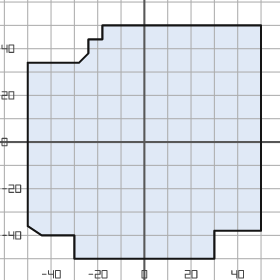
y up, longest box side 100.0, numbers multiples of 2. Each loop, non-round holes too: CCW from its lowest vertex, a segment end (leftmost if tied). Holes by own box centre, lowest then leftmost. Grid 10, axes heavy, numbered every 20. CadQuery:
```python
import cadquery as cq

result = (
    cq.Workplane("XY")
    .moveTo(-30.0, -50.0)
    .lineTo(30.0, -50.0)
    .lineTo(30.0, -38.0)
    .lineTo(50.0, -38.0)
    .lineTo(50.0, 50.0)
    .lineTo(-18.0, 50.0)
    .lineTo(-18.0, 44.0)
    .lineTo(-24.0, 44.0)
    .lineTo(-24.0, 38.0)
    .lineTo(-28.0, 34.0)
    .lineTo(-50.0, 34.0)
    .lineTo(-50.0, -36.0)
    .lineTo(-44.0, -40.0)
    .lineTo(-30.0, -40.0)
    .close()
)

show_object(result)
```